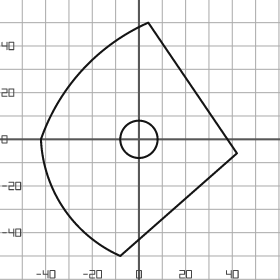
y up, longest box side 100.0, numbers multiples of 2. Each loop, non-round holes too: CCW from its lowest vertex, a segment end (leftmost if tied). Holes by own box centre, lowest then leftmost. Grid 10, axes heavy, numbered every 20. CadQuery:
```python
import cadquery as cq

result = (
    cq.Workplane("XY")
    .moveTo(-8.0, -50.0)
    .lineTo(42.0, -6.0)
    .lineTo(4.0, 50.0)
    .threePointArc((-24.0, 30.0), (-42.0, 0.0))
    .threePointArc((-32.0, -30.0), (-8.0, -50.0))
    .close()
    .moveTo(0.0, 0.0)
    .circle(8.0)
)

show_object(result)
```